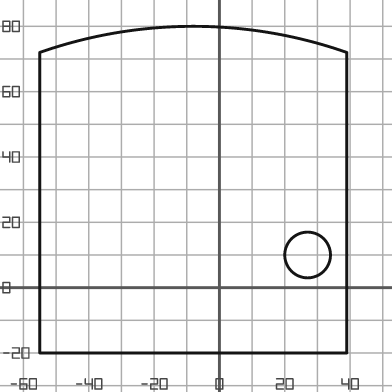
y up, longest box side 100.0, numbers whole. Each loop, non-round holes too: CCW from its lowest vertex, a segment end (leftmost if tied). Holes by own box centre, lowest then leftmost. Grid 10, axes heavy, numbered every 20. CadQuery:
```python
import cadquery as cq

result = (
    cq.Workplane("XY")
    .moveTo(-55.0, -20.0)
    .lineTo(39.0, -20.0)
    .lineTo(39.0, 72.0)
    .threePointArc((-8.0, 80.0), (-55.0, 72.0))
    .close()
    .moveTo(27.0, 10.0)
    .circle(7.0)
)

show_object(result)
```